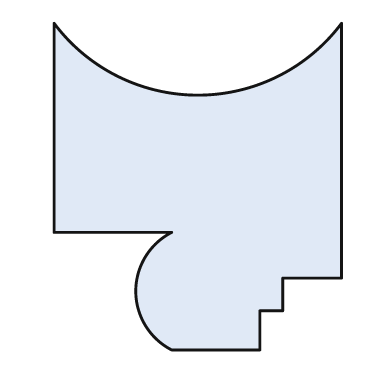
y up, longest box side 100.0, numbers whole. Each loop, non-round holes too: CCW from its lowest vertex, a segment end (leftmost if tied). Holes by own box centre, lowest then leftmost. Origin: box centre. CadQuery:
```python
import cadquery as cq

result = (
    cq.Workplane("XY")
    .moveTo(-8.0, -50.0)
    .lineTo(19.0, -50.0)
    .lineTo(19.0, -38.0)
    .lineTo(26.0, -38.0)
    .lineTo(26.0, -28.0)
    .lineTo(44.0, -28.0)
    .lineTo(44.0, 50.0)
    .threePointArc((0.0, 28.0), (-44.0, 50.0))
    .lineTo(-44.0, -14.0)
    .lineTo(-8.0, -14.0)
    .threePointArc((-19.0, -32.0), (-8.0, -50.0))
    .close()
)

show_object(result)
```